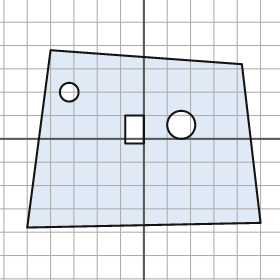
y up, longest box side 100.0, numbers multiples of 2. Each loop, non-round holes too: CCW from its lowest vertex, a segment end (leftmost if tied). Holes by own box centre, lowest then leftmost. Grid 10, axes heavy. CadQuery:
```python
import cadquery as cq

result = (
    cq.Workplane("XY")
    .moveTo(-50.0, -38.0)
    .lineTo(50.0, -36.0)
    .lineTo(42.0, 32.0)
    .lineTo(-40.0, 38.0)
    .close()
    .moveTo(-8.0, -2.0)
    .lineTo(0.0, -2.0)
    .lineTo(0.0, 10.0)
    .lineTo(-8.0, 10.0)
    .close()
    .moveTo(16.0, 6.0)
    .circle(6.0)
    .moveTo(-32.0, 20.0)
    .circle(4.0)
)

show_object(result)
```